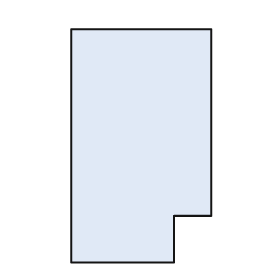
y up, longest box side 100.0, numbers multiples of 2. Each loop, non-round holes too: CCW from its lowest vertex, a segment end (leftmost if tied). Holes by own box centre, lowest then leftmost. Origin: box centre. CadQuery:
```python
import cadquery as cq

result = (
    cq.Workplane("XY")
    .moveTo(-30.0, -50.0)
    .lineTo(14.0, -50.0)
    .lineTo(14.0, -30.0)
    .lineTo(30.0, -30.0)
    .lineTo(30.0, 50.0)
    .lineTo(-30.0, 50.0)
    .close()
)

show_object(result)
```